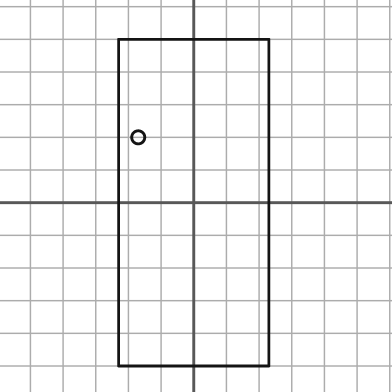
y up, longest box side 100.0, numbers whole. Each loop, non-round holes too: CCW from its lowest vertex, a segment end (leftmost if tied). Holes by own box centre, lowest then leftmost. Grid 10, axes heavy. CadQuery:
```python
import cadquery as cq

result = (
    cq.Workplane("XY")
    .moveTo(-23.0, -50.0)
    .lineTo(23.0, -50.0)
    .lineTo(23.0, 50.0)
    .lineTo(-23.0, 50.0)
    .close()
    .moveTo(-17.0, 20.0)
    .circle(2.0)
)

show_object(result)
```